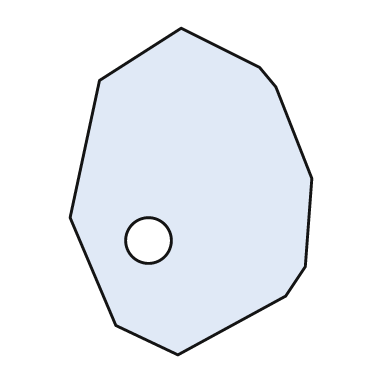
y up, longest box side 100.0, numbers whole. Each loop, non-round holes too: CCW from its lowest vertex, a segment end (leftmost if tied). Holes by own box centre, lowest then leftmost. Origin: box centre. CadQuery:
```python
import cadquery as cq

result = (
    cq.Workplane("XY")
    .moveTo(-4.0, -50.0)
    .lineTo(29.0, -32.0)
    .lineTo(35.0, -23.0)
    .lineTo(37.0, 4.0)
    .lineTo(26.0, 32.0)
    .lineTo(21.0, 38.0)
    .lineTo(-3.0, 50.0)
    .lineTo(-28.0, 34.0)
    .lineTo(-37.0, -8.0)
    .lineTo(-23.0, -41.0)
    .close()
    .moveTo(-13.0, -15.0)
    .circle(7.0)
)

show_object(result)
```